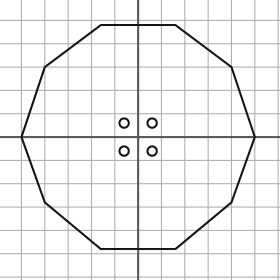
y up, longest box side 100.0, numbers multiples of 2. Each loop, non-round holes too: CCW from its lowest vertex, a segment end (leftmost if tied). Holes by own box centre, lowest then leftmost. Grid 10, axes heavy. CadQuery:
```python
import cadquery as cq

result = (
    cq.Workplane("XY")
    .moveTo(-16.0, -48.0)
    .lineTo(16.0, -48.0)
    .lineTo(40.0, -28.0)
    .lineTo(50.0, 0.0)
    .lineTo(40.0, 30.0)
    .lineTo(16.0, 48.0)
    .lineTo(-16.0, 48.0)
    .lineTo(-40.0, 30.0)
    .lineTo(-50.0, 0.0)
    .lineTo(-40.0, -28.0)
    .close()
    .moveTo(-6.0, -6.0)
    .circle(2.0)
    .moveTo(6.0, -6.0)
    .circle(2.0)
    .moveTo(-6.0, 6.0)
    .circle(2.0)
    .moveTo(6.0, 6.0)
    .circle(2.0)
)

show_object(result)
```